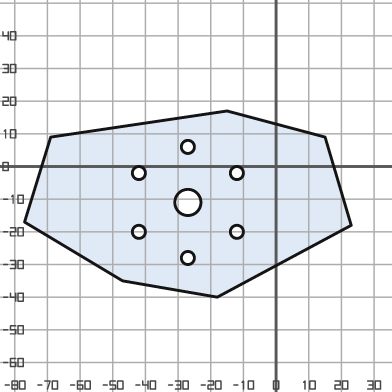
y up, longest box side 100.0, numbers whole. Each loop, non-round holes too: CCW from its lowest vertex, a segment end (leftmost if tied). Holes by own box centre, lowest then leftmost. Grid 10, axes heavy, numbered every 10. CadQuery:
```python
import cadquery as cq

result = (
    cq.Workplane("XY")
    .moveTo(-18.0, -40.0)
    .lineTo(23.0, -18.0)
    .lineTo(15.0, 9.0)
    .lineTo(-15.0, 17.0)
    .lineTo(-69.0, 9.0)
    .lineTo(-77.0, -17.0)
    .lineTo(-47.0, -35.0)
    .close()
    .moveTo(-27.0, -28.0)
    .circle(2.0)
    .moveTo(-42.0, -20.0)
    .circle(2.0)
    .moveTo(-12.0, -20.0)
    .circle(2.0)
    .moveTo(-27.0, -11.0)
    .circle(4.0)
    .moveTo(-42.0, -2.0)
    .circle(2.0)
    .moveTo(-12.0, -2.0)
    .circle(2.0)
    .moveTo(-27.0, 6.0)
    .circle(2.0)
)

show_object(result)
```